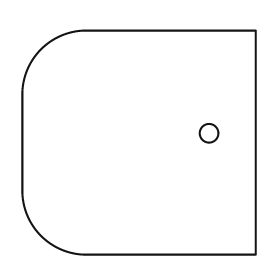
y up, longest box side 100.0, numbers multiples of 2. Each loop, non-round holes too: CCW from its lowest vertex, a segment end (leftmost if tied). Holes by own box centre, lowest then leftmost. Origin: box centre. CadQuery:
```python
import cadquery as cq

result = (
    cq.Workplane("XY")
    .moveTo(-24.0, -48.0)
    .lineTo(50.0, -48.0)
    .lineTo(50.0, 48.0)
    .lineTo(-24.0, 48.0)
    .threePointArc((-42.0, 40.0), (-50.0, 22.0))
    .lineTo(-50.0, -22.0)
    .threePointArc((-42.0, -40.0), (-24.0, -48.0))
    .close()
    .moveTo(30.0, 4.0)
    .circle(4.0)
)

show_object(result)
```